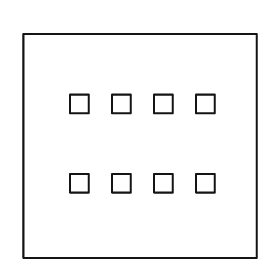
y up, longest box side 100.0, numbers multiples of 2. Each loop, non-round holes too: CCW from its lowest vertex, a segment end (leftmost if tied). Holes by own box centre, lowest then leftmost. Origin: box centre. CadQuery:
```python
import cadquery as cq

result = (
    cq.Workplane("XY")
    .moveTo(-50.0, -48.0)
    .lineTo(50.0, -48.0)
    .lineTo(50.0, 48.0)
    .lineTo(-50.0, 48.0)
    .close()
    .moveTo(-30.0, -20.0)
    .lineTo(-22.0, -20.0)
    .lineTo(-22.0, -12.0)
    .lineTo(-30.0, -12.0)
    .close()
    .moveTo(-12.0, -20.0)
    .lineTo(-4.0, -20.0)
    .lineTo(-4.0, -12.0)
    .lineTo(-12.0, -12.0)
    .close()
    .moveTo(6.0, -20.0)
    .lineTo(14.0, -20.0)
    .lineTo(14.0, -12.0)
    .lineTo(6.0, -12.0)
    .close()
    .moveTo(24.0, -20.0)
    .lineTo(32.0, -20.0)
    .lineTo(32.0, -12.0)
    .lineTo(24.0, -12.0)
    .close()
    .moveTo(-30.0, 14.0)
    .lineTo(-22.0, 14.0)
    .lineTo(-22.0, 22.0)
    .lineTo(-30.0, 22.0)
    .close()
    .moveTo(-12.0, 14.0)
    .lineTo(-4.0, 14.0)
    .lineTo(-4.0, 22.0)
    .lineTo(-12.0, 22.0)
    .close()
    .moveTo(6.0, 14.0)
    .lineTo(14.0, 14.0)
    .lineTo(14.0, 22.0)
    .lineTo(6.0, 22.0)
    .close()
    .moveTo(24.0, 14.0)
    .lineTo(32.0, 14.0)
    .lineTo(32.0, 22.0)
    .lineTo(24.0, 22.0)
    .close()
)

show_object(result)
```